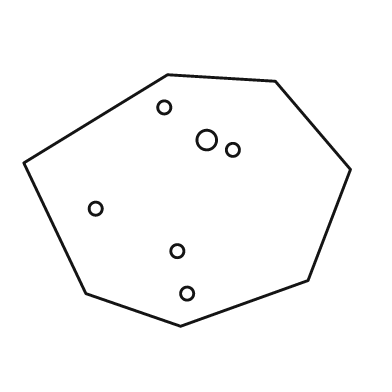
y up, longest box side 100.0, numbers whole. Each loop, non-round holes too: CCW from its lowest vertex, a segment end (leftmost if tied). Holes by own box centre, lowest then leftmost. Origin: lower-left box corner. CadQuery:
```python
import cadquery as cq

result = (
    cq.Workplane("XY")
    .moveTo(48.0, 0.0)
    .lineTo(87.0, 14.0)
    .lineTo(100.0, 48.0)
    .lineTo(77.0, 75.0)
    .lineTo(44.0, 77.0)
    .lineTo(0.0, 50.0)
    .lineTo(19.0, 10.0)
    .close()
    .moveTo(50.0, 10.0)
    .circle(2.0)
    .moveTo(47.0, 23.0)
    .circle(2.0)
    .moveTo(22.0, 36.0)
    .circle(2.0)
    .moveTo(64.0, 54.0)
    .circle(2.0)
    .moveTo(56.0, 57.0)
    .circle(3.0)
    .moveTo(43.0, 67.0)
    .circle(2.0)
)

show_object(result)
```